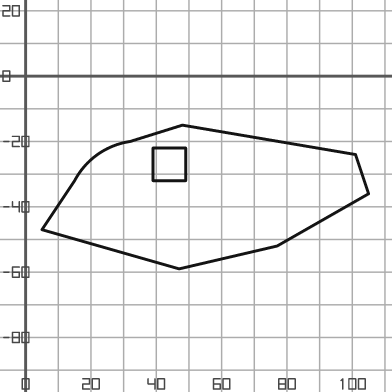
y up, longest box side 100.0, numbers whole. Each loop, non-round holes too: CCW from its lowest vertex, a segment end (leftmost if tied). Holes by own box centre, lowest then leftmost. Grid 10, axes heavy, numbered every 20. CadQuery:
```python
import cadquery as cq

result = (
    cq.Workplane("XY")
    .moveTo(47.0, -59.0)
    .lineTo(77.0, -52.0)
    .lineTo(105.0, -36.0)
    .lineTo(101.0, -24.0)
    .lineTo(48.0, -15.0)
    .lineTo(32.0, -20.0)
    .threePointArc((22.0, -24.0), (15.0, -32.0))
    .lineTo(5.0, -47.0)
    .close()
    .moveTo(39.0, -32.0)
    .lineTo(49.0, -32.0)
    .lineTo(49.0, -22.0)
    .lineTo(39.0, -22.0)
    .close()
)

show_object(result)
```